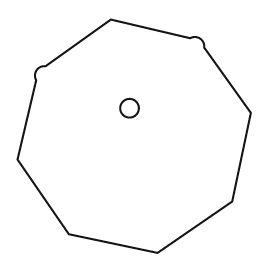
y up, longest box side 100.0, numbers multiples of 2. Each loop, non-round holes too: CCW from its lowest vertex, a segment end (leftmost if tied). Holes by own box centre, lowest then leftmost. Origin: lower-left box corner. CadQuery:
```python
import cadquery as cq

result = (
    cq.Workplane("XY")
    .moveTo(60.0, 0.0)
    .lineTo(92.0, 22.0)
    .lineTo(100.0, 60.0)
    .lineTo(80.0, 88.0)
    .threePointArc((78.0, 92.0), (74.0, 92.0))
    .lineTo(40.0, 100.0)
    .lineTo(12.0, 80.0)
    .threePointArc((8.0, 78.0), (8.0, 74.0))
    .lineTo(0.0, 40.0)
    .lineTo(22.0, 8.0)
    .close()
    .moveTo(48.0, 62.0)
    .circle(4.0)
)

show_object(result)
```